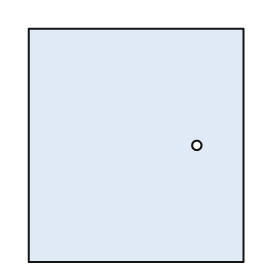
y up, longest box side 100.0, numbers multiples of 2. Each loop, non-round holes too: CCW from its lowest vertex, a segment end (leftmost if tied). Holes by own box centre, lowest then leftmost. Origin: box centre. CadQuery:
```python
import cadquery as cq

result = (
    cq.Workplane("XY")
    .moveTo(-46.0, -50.0)
    .lineTo(46.0, -50.0)
    .lineTo(46.0, 50.0)
    .lineTo(-46.0, 50.0)
    .close()
    .moveTo(26.0, 0.0)
    .circle(2.0)
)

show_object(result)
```